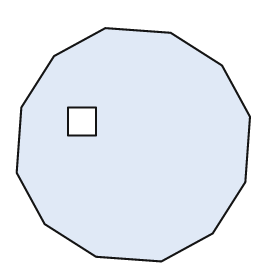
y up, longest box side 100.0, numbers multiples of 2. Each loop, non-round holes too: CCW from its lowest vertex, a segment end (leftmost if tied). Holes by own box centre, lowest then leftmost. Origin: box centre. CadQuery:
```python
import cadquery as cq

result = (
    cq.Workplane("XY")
    .moveTo(12.0, -50.0)
    .lineTo(34.0, -38.0)
    .lineTo(48.0, -16.0)
    .lineTo(50.0, 12.0)
    .lineTo(38.0, 34.0)
    .lineTo(16.0, 48.0)
    .lineTo(-12.0, 50.0)
    .lineTo(-34.0, 38.0)
    .lineTo(-48.0, 16.0)
    .lineTo(-50.0, -12.0)
    .lineTo(-38.0, -34.0)
    .lineTo(-16.0, -48.0)
    .close()
    .moveTo(-28.0, 4.0)
    .lineTo(-16.0, 4.0)
    .lineTo(-16.0, 16.0)
    .lineTo(-28.0, 16.0)
    .close()
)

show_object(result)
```